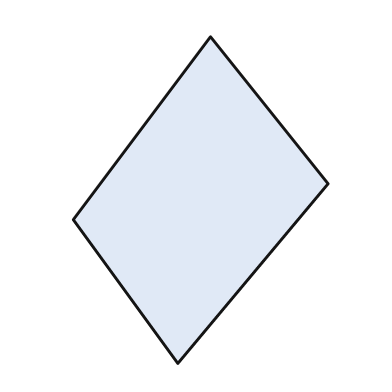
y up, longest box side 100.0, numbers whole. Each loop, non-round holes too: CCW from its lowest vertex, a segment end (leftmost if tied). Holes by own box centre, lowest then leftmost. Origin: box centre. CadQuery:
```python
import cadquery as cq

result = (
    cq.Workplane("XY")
    .moveTo(-7.0, -50.0)
    .lineTo(39.0, 5.0)
    .lineTo(3.0, 50.0)
    .lineTo(-39.0, -6.0)
    .close()
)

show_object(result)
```